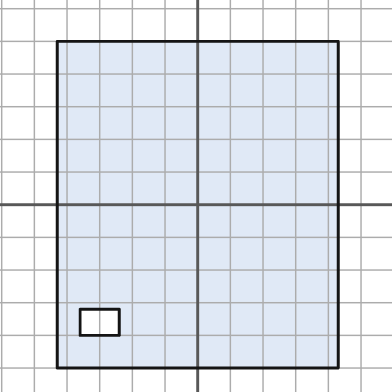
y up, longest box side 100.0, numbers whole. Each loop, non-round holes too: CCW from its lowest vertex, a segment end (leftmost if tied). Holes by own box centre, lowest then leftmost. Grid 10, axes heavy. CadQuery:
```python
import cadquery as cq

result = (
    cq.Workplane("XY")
    .moveTo(-43.0, -50.0)
    .lineTo(43.0, -50.0)
    .lineTo(43.0, 50.0)
    .lineTo(-43.0, 50.0)
    .close()
    .moveTo(-36.0, -40.0)
    .lineTo(-24.0, -40.0)
    .lineTo(-24.0, -32.0)
    .lineTo(-36.0, -32.0)
    .close()
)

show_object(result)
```